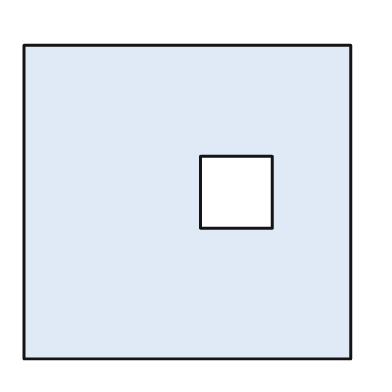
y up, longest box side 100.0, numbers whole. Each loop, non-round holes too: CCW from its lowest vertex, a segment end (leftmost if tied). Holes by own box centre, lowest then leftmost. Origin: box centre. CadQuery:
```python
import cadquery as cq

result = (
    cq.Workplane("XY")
    .moveTo(-50.0, -48.0)
    .lineTo(50.0, -48.0)
    .lineTo(50.0, 48.0)
    .lineTo(-50.0, 48.0)
    .close()
    .moveTo(4.0, -8.0)
    .lineTo(26.0, -8.0)
    .lineTo(26.0, 14.0)
    .lineTo(4.0, 14.0)
    .close()
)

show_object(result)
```